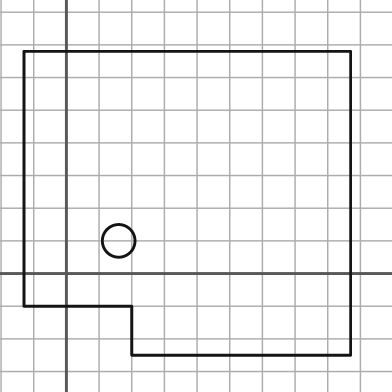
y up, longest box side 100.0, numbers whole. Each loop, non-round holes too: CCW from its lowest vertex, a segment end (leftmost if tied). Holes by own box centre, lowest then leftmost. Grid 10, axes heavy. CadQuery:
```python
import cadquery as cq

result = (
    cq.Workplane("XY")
    .moveTo(20.0, -25.0)
    .lineTo(87.0, -25.0)
    .lineTo(87.0, 68.0)
    .lineTo(-13.0, 68.0)
    .lineTo(-13.0, -10.0)
    .lineTo(20.0, -10.0)
    .close()
    .moveTo(16.0, 10.0)
    .circle(5.0)
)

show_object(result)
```